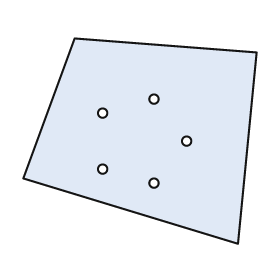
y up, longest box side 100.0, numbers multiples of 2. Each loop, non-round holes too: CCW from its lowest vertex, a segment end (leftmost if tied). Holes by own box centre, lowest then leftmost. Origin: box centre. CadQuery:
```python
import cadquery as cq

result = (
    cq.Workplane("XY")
    .moveTo(42.0, -44.0)
    .lineTo(50.0, 38.0)
    .lineTo(-28.0, 44.0)
    .lineTo(-50.0, -16.0)
    .close()
    .moveTo(6.0, -18.0)
    .circle(2.0)
    .moveTo(-16.0, -12.0)
    .circle(2.0)
    .moveTo(20.0, 0.0)
    .circle(2.0)
    .moveTo(-16.0, 12.0)
    .circle(2.0)
    .moveTo(6.0, 18.0)
    .circle(2.0)
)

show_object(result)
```